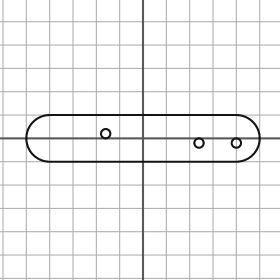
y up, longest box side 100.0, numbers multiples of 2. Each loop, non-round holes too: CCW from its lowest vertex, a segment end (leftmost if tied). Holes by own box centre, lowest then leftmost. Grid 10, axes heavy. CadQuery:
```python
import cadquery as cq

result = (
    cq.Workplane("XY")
    .moveTo(-40.0, -10.0)
    .lineTo(40.0, -10.0)
    .threePointArc((50.0, 0.0), (40.0, 10.0))
    .lineTo(-40.0, 10.0)
    .threePointArc((-50.0, 0.0), (-40.0, -10.0))
    .close()
    .moveTo(24.0, -2.0)
    .circle(2.0)
    .moveTo(40.0, -2.0)
    .circle(2.0)
    .moveTo(-16.0, 2.0)
    .circle(2.0)
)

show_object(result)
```